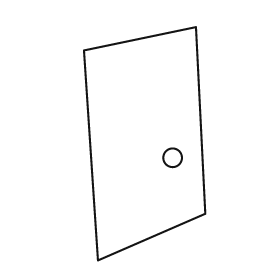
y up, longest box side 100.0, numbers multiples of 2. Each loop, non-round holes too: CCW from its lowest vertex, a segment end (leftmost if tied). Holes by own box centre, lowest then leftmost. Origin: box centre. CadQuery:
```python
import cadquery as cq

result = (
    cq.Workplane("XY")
    .moveTo(-20.0, -50.0)
    .lineTo(26.0, -30.0)
    .lineTo(22.0, 50.0)
    .lineTo(-26.0, 40.0)
    .close()
    .moveTo(12.0, -6.0)
    .circle(4.0)
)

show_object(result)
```